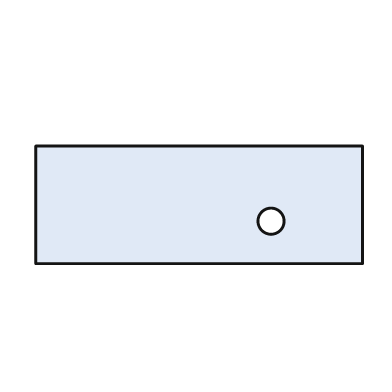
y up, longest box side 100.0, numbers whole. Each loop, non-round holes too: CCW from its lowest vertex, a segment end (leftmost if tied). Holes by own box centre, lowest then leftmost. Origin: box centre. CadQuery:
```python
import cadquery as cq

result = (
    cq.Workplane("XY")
    .moveTo(-50.0, -18.0)
    .lineTo(50.0, -18.0)
    .lineTo(50.0, 18.0)
    .lineTo(-50.0, 18.0)
    .close()
    .moveTo(22.0, -5.0)
    .circle(4.0)
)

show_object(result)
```